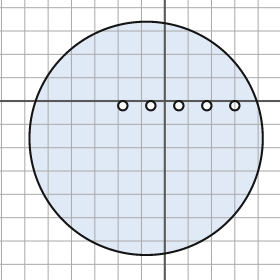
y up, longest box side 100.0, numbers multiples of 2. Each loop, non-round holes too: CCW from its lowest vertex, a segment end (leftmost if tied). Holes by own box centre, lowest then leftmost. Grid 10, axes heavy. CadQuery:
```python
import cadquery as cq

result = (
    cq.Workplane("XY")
    .moveTo(-8.0, -16.0)
    .circle(50.0)
    .moveTo(-18.0, -2.0)
    .circle(2.0)
    .moveTo(-6.0, -2.0)
    .circle(2.0)
    .moveTo(6.0, -2.0)
    .circle(2.0)
    .moveTo(18.0, -2.0)
    .circle(2.0)
    .moveTo(30.0, -2.0)
    .circle(2.0)
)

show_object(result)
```